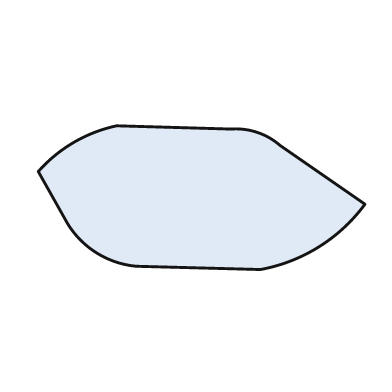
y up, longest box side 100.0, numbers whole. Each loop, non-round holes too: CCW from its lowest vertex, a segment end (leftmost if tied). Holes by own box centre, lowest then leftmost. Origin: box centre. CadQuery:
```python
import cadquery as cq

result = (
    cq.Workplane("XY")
    .moveTo(18.0, -22.0)
    .threePointArc((36.0, -15.0), (50.0, -2.0))
    .lineTo(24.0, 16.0)
    .threePointArc((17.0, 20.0), (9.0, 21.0))
    .lineTo(-26.0, 22.0)
    .threePointArc((-39.0, 17.0), (-50.0, 8.0))
    .lineTo(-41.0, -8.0)
    .threePointArc((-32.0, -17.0), (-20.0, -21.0))
    .close()
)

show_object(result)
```